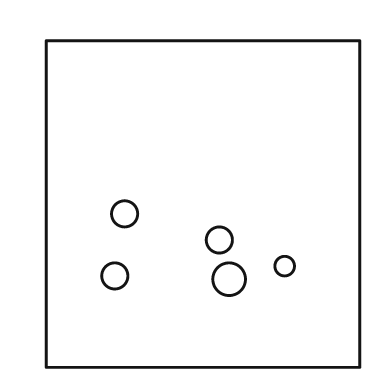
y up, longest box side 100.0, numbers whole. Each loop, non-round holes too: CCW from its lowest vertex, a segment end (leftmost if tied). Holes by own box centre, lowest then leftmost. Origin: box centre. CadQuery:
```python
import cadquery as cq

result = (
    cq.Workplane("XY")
    .moveTo(-48.0, -50.0)
    .lineTo(48.0, -50.0)
    .lineTo(48.0, 50.0)
    .lineTo(-48.0, 50.0)
    .close()
    .moveTo(8.0, -23.0)
    .circle(5.0)
    .moveTo(-27.0, -22.0)
    .circle(4.0)
    .moveTo(25.0, -19.0)
    .circle(3.0)
    .moveTo(5.0, -11.0)
    .circle(4.0)
    .moveTo(-24.0, -3.0)
    .circle(4.0)
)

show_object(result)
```